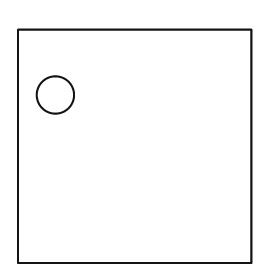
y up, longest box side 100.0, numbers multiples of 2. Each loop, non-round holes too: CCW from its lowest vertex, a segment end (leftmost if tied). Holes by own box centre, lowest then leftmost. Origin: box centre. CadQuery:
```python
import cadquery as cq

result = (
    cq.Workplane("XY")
    .moveTo(-50.0, -50.0)
    .lineTo(50.0, -50.0)
    .lineTo(50.0, 50.0)
    .lineTo(-50.0, 50.0)
    .close()
    .moveTo(-34.0, 22.0)
    .circle(8.0)
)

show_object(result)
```